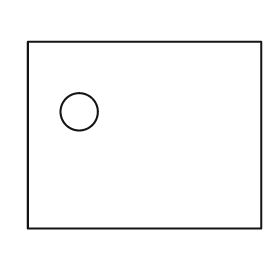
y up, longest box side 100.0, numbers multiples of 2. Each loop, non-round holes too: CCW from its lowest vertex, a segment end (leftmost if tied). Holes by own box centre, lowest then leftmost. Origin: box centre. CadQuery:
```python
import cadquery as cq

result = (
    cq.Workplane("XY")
    .moveTo(-50.0, -40.0)
    .lineTo(50.0, -40.0)
    .lineTo(50.0, 40.0)
    .lineTo(-50.0, 40.0)
    .close()
    .moveTo(-28.0, 10.0)
    .circle(8.0)
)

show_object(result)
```